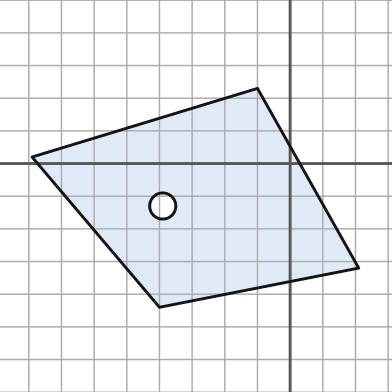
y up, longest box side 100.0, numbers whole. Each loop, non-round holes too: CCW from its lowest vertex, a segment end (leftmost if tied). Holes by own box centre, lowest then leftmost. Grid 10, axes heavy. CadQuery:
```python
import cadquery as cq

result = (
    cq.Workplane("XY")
    .moveTo(-40.0, -44.0)
    .lineTo(21.0, -32.0)
    .lineTo(-10.0, 23.0)
    .lineTo(-79.0, 2.0)
    .close()
    .moveTo(-39.0, -13.0)
    .circle(4.0)
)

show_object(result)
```